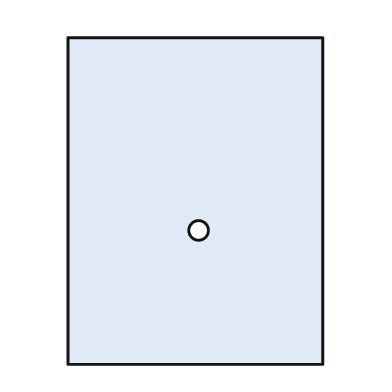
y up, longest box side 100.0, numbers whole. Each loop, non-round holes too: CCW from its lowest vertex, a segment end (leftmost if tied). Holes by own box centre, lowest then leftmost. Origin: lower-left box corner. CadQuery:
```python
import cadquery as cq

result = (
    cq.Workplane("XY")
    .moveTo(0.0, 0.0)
    .lineTo(78.0, 0.0)
    .lineTo(78.0, 100.0)
    .lineTo(0.0, 100.0)
    .close()
    .moveTo(40.0, 41.0)
    .circle(3.0)
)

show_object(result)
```